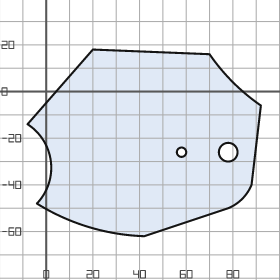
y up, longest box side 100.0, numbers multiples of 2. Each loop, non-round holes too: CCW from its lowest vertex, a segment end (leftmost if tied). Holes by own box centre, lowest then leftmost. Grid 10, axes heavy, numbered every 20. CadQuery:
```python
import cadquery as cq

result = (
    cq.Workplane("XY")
    .moveTo(42.0, -62.0)
    .lineTo(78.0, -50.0)
    .threePointArc((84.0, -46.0), (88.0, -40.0))
    .lineTo(92.0, -6.0)
    .threePointArc((80.0, 4.0), (70.0, 16.0))
    .lineTo(20.0, 18.0)
    .lineTo(-8.0, -14.0)
    .threePointArc((2.0, -30.0), (-4.0, -48.0))
    .threePointArc((18.0, -58.0), (42.0, -62.0))
    .close()
    .moveTo(58.0, -26.0)
    .circle(2.0)
    .moveTo(78.0, -26.0)
    .circle(4.0)
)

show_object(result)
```